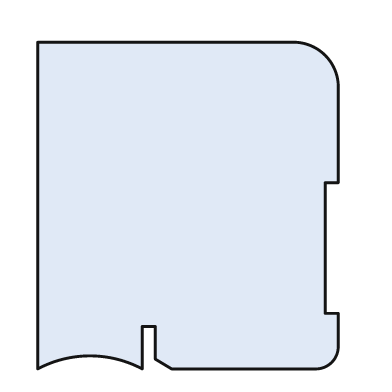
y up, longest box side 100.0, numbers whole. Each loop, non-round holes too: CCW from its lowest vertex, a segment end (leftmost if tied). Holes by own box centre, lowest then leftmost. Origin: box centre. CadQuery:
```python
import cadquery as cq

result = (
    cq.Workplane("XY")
    .moveTo(-46.0, -50.0)
    .threePointArc((-30.0, -46.0), (-14.0, -50.0))
    .lineTo(-14.0, -37.0)
    .lineTo(-10.0, -37.0)
    .lineTo(-10.0, -47.0)
    .lineTo(-5.0, -50.0)
    .lineTo(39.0, -50.0)
    .threePointArc((44.0, -48.0), (46.0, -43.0))
    .lineTo(46.0, -33.0)
    .lineTo(42.0, -33.0)
    .lineTo(42.0, 7.0)
    .lineTo(46.0, 7.0)
    .lineTo(46.0, 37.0)
    .threePointArc((42.0, 46.0), (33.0, 50.0))
    .lineTo(-46.0, 50.0)
    .close()
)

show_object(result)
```